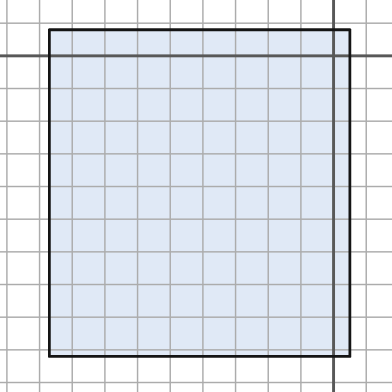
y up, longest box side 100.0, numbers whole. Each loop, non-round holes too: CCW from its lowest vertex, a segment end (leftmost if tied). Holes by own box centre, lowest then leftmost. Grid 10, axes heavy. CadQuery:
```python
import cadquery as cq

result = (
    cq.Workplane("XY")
    .moveTo(-87.0, -92.0)
    .lineTo(5.0, -92.0)
    .lineTo(5.0, 8.0)
    .lineTo(-87.0, 8.0)
    .close()
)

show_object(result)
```